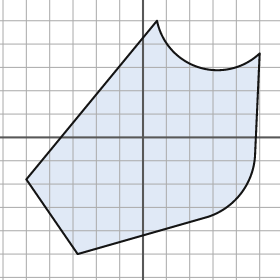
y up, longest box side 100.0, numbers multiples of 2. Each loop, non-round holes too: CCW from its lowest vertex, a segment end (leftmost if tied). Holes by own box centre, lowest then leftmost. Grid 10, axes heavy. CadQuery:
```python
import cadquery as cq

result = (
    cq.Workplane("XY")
    .moveTo(-28.0, -50.0)
    .lineTo(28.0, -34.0)
    .threePointArc((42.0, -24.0), (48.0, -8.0))
    .lineTo(50.0, 36.0)
    .threePointArc((24.0, 30.0), (6.0, 50.0))
    .lineTo(-50.0, -18.0)
    .close()
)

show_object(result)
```